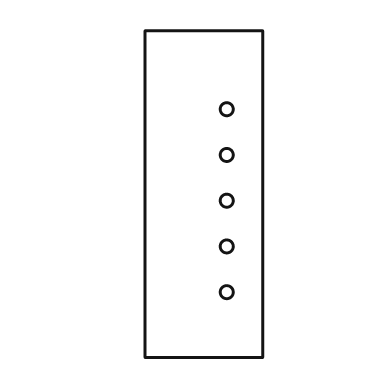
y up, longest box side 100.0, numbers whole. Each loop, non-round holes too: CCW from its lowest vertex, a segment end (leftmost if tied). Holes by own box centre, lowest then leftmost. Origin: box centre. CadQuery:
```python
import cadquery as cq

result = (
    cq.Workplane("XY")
    .moveTo(-18.0, -50.0)
    .lineTo(18.0, -50.0)
    .lineTo(18.0, 50.0)
    .lineTo(-18.0, 50.0)
    .close()
    .moveTo(7.0, -30.0)
    .circle(2.0)
    .moveTo(7.0, -16.0)
    .circle(2.0)
    .moveTo(7.0, -2.0)
    .circle(2.0)
    .moveTo(7.0, 12.0)
    .circle(2.0)
    .moveTo(7.0, 26.0)
    .circle(2.0)
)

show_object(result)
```